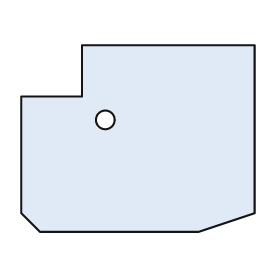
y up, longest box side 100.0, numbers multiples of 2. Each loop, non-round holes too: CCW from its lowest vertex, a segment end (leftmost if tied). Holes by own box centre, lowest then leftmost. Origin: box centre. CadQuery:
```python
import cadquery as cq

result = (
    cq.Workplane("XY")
    .moveTo(-42.0, -40.0)
    .lineTo(26.0, -40.0)
    .lineTo(50.0, -32.0)
    .lineTo(50.0, 40.0)
    .lineTo(-24.0, 40.0)
    .lineTo(-24.0, 18.0)
    .lineTo(-50.0, 18.0)
    .lineTo(-50.0, -32.0)
    .close()
    .moveTo(-14.0, 8.0)
    .circle(4.0)
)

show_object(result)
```